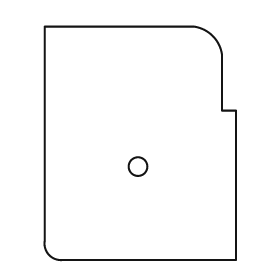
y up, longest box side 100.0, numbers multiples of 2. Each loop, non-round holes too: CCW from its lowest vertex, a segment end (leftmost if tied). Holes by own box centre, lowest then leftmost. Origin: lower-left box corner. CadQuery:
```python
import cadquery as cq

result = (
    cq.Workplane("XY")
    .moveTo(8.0, 0.0)
    .lineTo(82.0, 0.0)
    .lineTo(82.0, 64.0)
    .lineTo(76.0, 64.0)
    .lineTo(76.0, 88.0)
    .threePointArc((72.0, 96.0), (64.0, 100.0))
    .lineTo(0.0, 100.0)
    .lineTo(0.0, 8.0)
    .threePointArc((2.0, 2.0), (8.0, 0.0))
    .close()
    .moveTo(40.0, 40.0)
    .circle(4.0)
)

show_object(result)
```